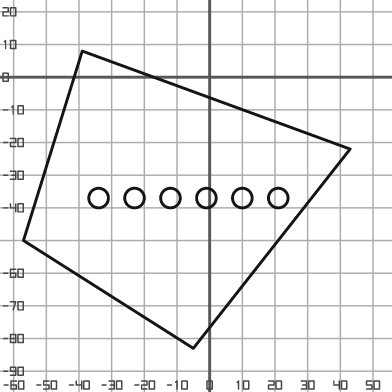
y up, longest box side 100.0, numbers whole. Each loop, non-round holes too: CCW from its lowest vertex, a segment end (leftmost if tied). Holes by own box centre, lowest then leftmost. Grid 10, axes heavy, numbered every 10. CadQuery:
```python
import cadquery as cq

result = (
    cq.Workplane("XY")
    .moveTo(-5.0, -83.0)
    .lineTo(43.0, -22.0)
    .lineTo(-39.0, 8.0)
    .lineTo(-57.0, -50.0)
    .close()
    .moveTo(-34.0, -37.0)
    .circle(3.0)
    .moveTo(-23.0, -37.0)
    .circle(3.0)
    .moveTo(-12.0, -37.0)
    .circle(3.0)
    .moveTo(-1.0, -37.0)
    .circle(3.0)
    .moveTo(10.0, -37.0)
    .circle(3.0)
    .moveTo(21.0, -37.0)
    .circle(3.0)
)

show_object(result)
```